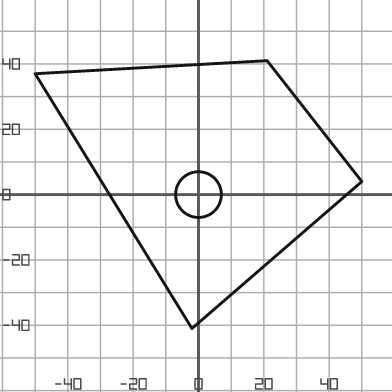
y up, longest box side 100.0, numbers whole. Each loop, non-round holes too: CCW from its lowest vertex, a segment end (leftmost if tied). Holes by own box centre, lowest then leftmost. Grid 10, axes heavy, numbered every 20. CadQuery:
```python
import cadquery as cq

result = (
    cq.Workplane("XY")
    .moveTo(-2.0, -41.0)
    .lineTo(50.0, 4.0)
    .lineTo(21.0, 41.0)
    .lineTo(-50.0, 37.0)
    .close()
    .moveTo(0.0, 0.0)
    .circle(7.0)
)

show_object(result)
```